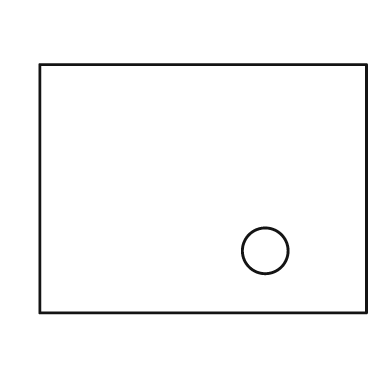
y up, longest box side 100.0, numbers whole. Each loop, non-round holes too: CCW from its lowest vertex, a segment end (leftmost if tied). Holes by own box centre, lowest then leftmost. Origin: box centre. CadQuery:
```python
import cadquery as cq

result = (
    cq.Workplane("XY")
    .moveTo(-50.0, -38.0)
    .lineTo(50.0, -38.0)
    .lineTo(50.0, 38.0)
    .lineTo(-50.0, 38.0)
    .close()
    .moveTo(19.0, -19.0)
    .circle(7.0)
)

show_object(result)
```